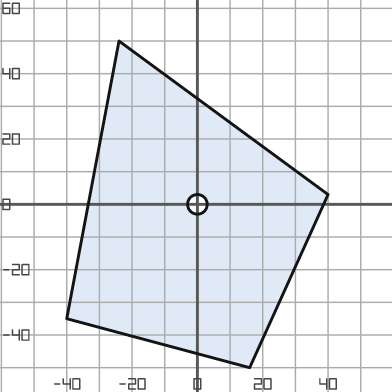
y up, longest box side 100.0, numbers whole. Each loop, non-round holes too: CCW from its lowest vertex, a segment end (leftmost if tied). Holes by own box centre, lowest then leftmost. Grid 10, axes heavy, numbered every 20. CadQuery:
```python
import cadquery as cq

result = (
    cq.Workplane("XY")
    .moveTo(16.0, -50.0)
    .lineTo(40.0, 3.0)
    .lineTo(-24.0, 50.0)
    .lineTo(-40.0, -35.0)
    .close()
    .moveTo(0.0, 0.0)
    .circle(3.0)
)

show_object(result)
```